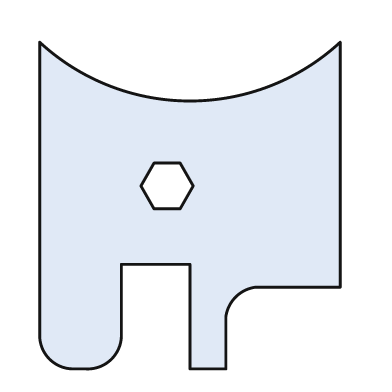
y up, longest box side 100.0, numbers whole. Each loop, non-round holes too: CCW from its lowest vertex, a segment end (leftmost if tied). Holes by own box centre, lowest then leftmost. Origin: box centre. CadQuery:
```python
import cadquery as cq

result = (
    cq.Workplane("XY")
    .moveTo(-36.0, -50.0)
    .lineTo(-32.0, -50.0)
    .threePointArc((-24.0, -47.0), (-21.0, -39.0))
    .lineTo(-21.0, -18.0)
    .lineTo(0.0, -18.0)
    .lineTo(0.0, -50.0)
    .lineTo(11.0, -50.0)
    .lineTo(11.0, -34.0)
    .threePointArc((14.0, -28.0), (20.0, -25.0))
    .lineTo(46.0, -25.0)
    .lineTo(46.0, 50.0)
    .threePointArc((0.0, 32.0), (-46.0, 50.0))
    .lineTo(-46.0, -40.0)
    .threePointArc((-43.0, -47.0), (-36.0, -50.0))
    .close()
    .moveTo(-11.0, -1.0)
    .lineTo(-3.0, -1.0)
    .lineTo(1.0, 6.0)
    .lineTo(-3.0, 13.0)
    .lineTo(-11.0, 13.0)
    .lineTo(-15.0, 6.0)
    .close()
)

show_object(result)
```